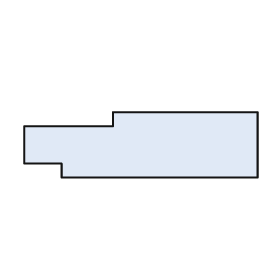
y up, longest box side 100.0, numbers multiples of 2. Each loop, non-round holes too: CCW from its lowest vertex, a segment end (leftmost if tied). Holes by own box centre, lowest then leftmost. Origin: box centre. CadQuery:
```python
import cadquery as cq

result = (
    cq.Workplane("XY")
    .moveTo(-34.0, -14.0)
    .lineTo(50.0, -14.0)
    .lineTo(50.0, 14.0)
    .lineTo(-12.0, 14.0)
    .lineTo(-12.0, 8.0)
    .lineTo(-50.0, 8.0)
    .lineTo(-50.0, -8.0)
    .lineTo(-34.0, -8.0)
    .close()
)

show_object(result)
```